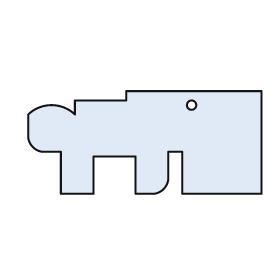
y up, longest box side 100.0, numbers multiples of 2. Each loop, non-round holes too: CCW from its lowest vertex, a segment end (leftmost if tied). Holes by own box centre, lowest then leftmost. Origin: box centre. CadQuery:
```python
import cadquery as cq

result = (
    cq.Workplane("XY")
    .moveTo(-36.0, -22.0)
    .lineTo(-22.0, -22.0)
    .lineTo(-22.0, -6.0)
    .lineTo(-4.0, -6.0)
    .lineTo(-4.0, -22.0)
    .lineTo(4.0, -22.0)
    .threePointArc((8.0, -20.0), (10.0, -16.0))
    .lineTo(10.0, -4.0)
    .lineTo(16.0, -4.0)
    .lineTo(16.0, -22.0)
    .lineTo(50.0, -22.0)
    .lineTo(50.0, 22.0)
    .lineTo(-8.0, 22.0)
    .lineTo(-8.0, 18.0)
    .lineTo(-30.0, 18.0)
    .lineTo(-30.0, 12.0)
    .threePointArc((-40.0, 16.0), (-50.0, 12.0))
    .lineTo(-50.0, 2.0)
    .threePointArc((-48.0, -2.0), (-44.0, -4.0))
    .lineTo(-36.0, -4.0)
    .close()
    .moveTo(20.0, 16.0)
    .circle(2.0)
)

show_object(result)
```